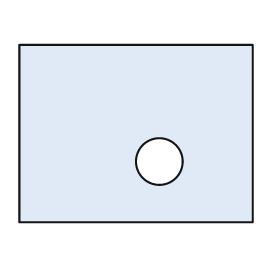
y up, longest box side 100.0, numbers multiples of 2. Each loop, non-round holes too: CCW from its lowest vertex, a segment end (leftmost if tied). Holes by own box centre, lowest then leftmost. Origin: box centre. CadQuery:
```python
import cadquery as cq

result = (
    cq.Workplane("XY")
    .moveTo(-50.0, -38.0)
    .lineTo(50.0, -38.0)
    .lineTo(50.0, 38.0)
    .lineTo(-50.0, 38.0)
    .close()
    .moveTo(10.0, -12.0)
    .circle(10.0)
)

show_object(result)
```